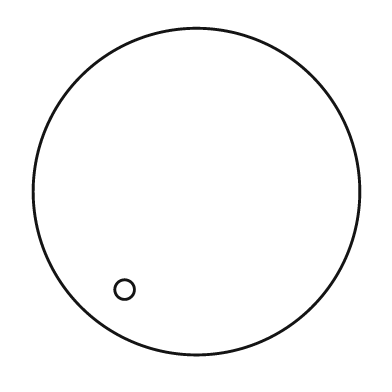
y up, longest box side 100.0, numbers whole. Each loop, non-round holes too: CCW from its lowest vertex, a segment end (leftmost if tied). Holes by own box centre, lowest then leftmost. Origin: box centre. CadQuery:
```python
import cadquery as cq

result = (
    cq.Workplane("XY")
    .moveTo(0.0, 0.0)
    .circle(50.0)
    .moveTo(-22.0, -30.0)
    .circle(3.0)
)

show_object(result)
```